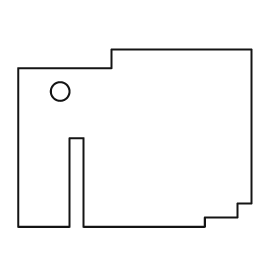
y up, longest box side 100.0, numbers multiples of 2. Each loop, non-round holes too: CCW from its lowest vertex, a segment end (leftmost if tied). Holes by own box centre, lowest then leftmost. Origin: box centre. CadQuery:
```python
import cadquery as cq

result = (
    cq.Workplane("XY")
    .moveTo(-50.0, -38.0)
    .lineTo(-28.0, -38.0)
    .lineTo(-28.0, 0.0)
    .lineTo(-22.0, 0.0)
    .lineTo(-22.0, -38.0)
    .lineTo(30.0, -38.0)
    .lineTo(30.0, -34.0)
    .lineTo(44.0, -34.0)
    .lineTo(44.0, -28.0)
    .lineTo(50.0, -28.0)
    .lineTo(50.0, 38.0)
    .lineTo(-10.0, 38.0)
    .lineTo(-10.0, 30.0)
    .lineTo(-50.0, 30.0)
    .close()
    .moveTo(-32.0, 20.0)
    .circle(4.0)
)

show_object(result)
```